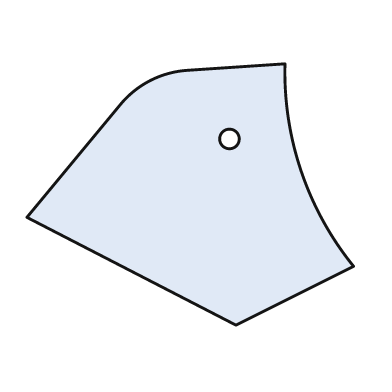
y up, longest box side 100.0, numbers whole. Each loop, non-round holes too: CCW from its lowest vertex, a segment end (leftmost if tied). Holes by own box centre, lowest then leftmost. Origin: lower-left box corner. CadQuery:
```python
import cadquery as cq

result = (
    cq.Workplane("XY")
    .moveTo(64.0, 0.0)
    .lineTo(100.0, 18.0)
    .threePointArc((84.0, 47.0), (79.0, 80.0))
    .lineTo(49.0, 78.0)
    .threePointArc((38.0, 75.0), (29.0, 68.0))
    .lineTo(0.0, 33.0)
    .close()
    .moveTo(62.0, 57.0)
    .circle(3.0)
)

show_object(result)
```